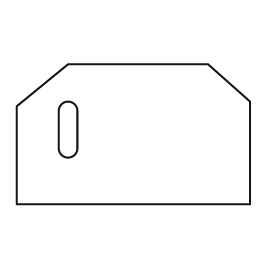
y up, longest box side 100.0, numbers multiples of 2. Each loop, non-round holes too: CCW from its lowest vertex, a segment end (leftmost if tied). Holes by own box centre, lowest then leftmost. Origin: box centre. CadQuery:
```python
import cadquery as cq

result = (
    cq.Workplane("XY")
    .moveTo(-50.0, -30.0)
    .lineTo(50.0, -30.0)
    .lineTo(50.0, 14.0)
    .lineTo(32.0, 30.0)
    .lineTo(-28.0, 30.0)
    .lineTo(-50.0, 12.0)
    .close()
    .moveTo(-32.0, -6.0)
    .threePointArc((-28.0, -10.0), (-24.0, -6.0))
    .lineTo(-24.0, 10.0)
    .threePointArc((-28.0, 14.0), (-32.0, 10.0))
    .close()
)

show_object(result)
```